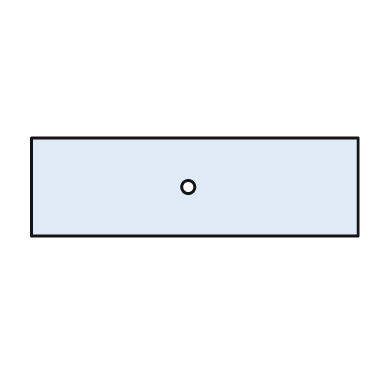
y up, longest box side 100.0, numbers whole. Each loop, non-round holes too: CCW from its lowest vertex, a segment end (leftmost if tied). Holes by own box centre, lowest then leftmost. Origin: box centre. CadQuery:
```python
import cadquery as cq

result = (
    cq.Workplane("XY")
    .moveTo(-50.0, -15.0)
    .lineTo(50.0, -15.0)
    .lineTo(50.0, 15.0)
    .lineTo(-50.0, 15.0)
    .close()
    .moveTo(-2.0, 0.0)
    .circle(2.0)
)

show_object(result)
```